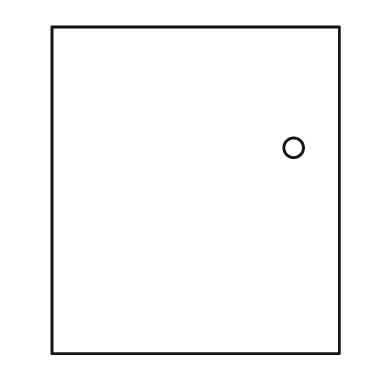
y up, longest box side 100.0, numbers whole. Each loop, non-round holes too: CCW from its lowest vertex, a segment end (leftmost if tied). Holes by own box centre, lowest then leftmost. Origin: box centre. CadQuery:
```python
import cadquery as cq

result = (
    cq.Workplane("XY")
    .moveTo(-44.0, -50.0)
    .lineTo(44.0, -50.0)
    .lineTo(44.0, 50.0)
    .lineTo(-44.0, 50.0)
    .close()
    .moveTo(30.0, 13.0)
    .circle(3.0)
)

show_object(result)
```